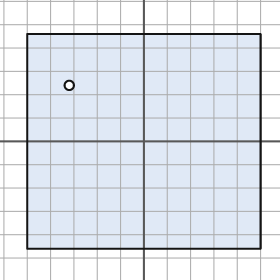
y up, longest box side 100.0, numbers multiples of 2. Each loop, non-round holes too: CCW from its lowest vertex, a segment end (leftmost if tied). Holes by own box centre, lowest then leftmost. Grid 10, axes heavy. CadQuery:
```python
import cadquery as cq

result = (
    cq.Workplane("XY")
    .moveTo(-50.0, -46.0)
    .lineTo(50.0, -46.0)
    .lineTo(50.0, 46.0)
    .lineTo(-50.0, 46.0)
    .close()
    .moveTo(-32.0, 24.0)
    .circle(2.0)
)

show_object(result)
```